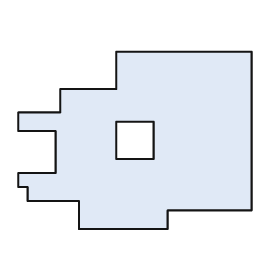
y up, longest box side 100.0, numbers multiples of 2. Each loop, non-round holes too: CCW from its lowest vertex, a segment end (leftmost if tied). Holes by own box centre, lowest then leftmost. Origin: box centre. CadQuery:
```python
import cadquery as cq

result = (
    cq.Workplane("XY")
    .moveTo(-24.0, -38.0)
    .lineTo(14.0, -38.0)
    .lineTo(14.0, -30.0)
    .lineTo(50.0, -30.0)
    .lineTo(50.0, 38.0)
    .lineTo(-8.0, 38.0)
    .lineTo(-8.0, 22.0)
    .lineTo(-32.0, 22.0)
    .lineTo(-32.0, 12.0)
    .lineTo(-50.0, 12.0)
    .lineTo(-50.0, 4.0)
    .lineTo(-34.0, 4.0)
    .lineTo(-34.0, -14.0)
    .lineTo(-50.0, -14.0)
    .lineTo(-50.0, -20.0)
    .lineTo(-46.0, -20.0)
    .lineTo(-46.0, -26.0)
    .lineTo(-24.0, -26.0)
    .close()
    .moveTo(-8.0, -8.0)
    .lineTo(8.0, -8.0)
    .lineTo(8.0, 8.0)
    .lineTo(-8.0, 8.0)
    .close()
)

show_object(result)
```